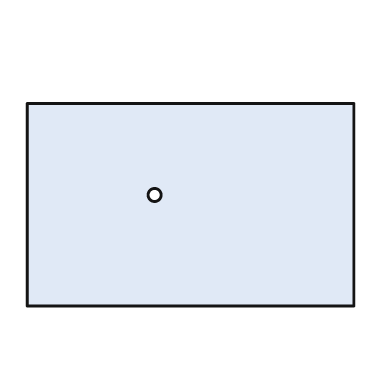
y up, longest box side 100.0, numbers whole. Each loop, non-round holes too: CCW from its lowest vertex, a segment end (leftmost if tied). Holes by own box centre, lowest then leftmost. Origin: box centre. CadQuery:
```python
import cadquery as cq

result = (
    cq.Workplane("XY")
    .moveTo(-50.0, -31.0)
    .lineTo(50.0, -31.0)
    .lineTo(50.0, 31.0)
    .lineTo(-50.0, 31.0)
    .close()
    .moveTo(-11.0, 3.0)
    .circle(2.0)
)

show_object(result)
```